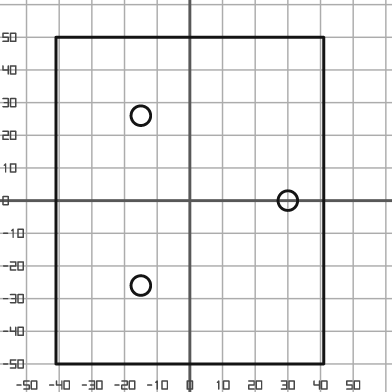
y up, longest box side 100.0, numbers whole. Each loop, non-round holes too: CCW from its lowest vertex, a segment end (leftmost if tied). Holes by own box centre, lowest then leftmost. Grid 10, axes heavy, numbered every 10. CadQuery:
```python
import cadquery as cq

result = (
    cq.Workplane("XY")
    .moveTo(-41.0, -50.0)
    .lineTo(41.0, -50.0)
    .lineTo(41.0, 50.0)
    .lineTo(-41.0, 50.0)
    .close()
    .moveTo(-15.0, -26.0)
    .circle(3.0)
    .moveTo(30.0, 0.0)
    .circle(3.0)
    .moveTo(-15.0, 26.0)
    .circle(3.0)
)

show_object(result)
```